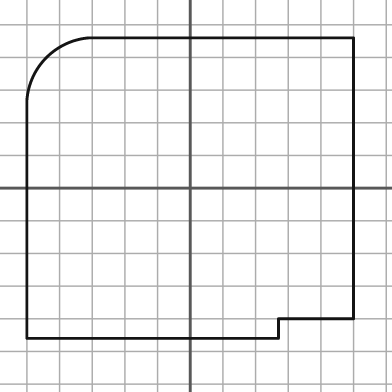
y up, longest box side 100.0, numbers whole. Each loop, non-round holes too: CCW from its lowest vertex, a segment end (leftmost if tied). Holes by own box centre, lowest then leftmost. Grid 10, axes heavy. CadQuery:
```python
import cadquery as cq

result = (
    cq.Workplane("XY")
    .moveTo(-50.0, -46.0)
    .lineTo(27.0, -46.0)
    .lineTo(27.0, -40.0)
    .lineTo(50.0, -40.0)
    .lineTo(50.0, 46.0)
    .lineTo(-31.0, 46.0)
    .threePointArc((-44.0, 40.0), (-50.0, 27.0))
    .close()
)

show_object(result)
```